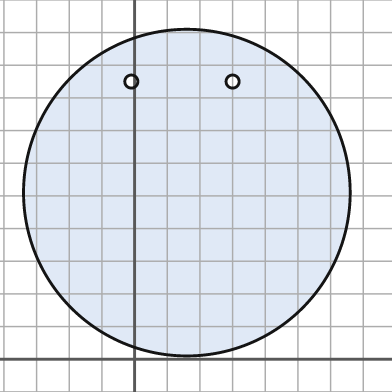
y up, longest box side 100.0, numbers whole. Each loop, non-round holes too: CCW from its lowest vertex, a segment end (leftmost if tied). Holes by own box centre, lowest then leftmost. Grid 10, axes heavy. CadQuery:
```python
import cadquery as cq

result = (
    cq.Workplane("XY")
    .moveTo(16.0, 51.0)
    .circle(50.0)
    .moveTo(-1.0, 85.0)
    .circle(2.0)
    .moveTo(30.0, 85.0)
    .circle(2.0)
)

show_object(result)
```